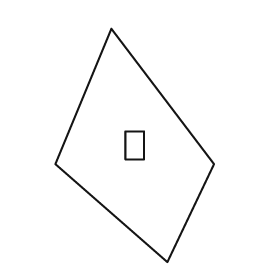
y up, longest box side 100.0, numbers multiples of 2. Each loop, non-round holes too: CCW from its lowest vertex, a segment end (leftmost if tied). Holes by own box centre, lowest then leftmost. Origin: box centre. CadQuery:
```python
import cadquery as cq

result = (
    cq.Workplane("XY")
    .moveTo(14.0, -50.0)
    .lineTo(34.0, -8.0)
    .lineTo(-10.0, 50.0)
    .lineTo(-34.0, -8.0)
    .close()
    .moveTo(-4.0, -6.0)
    .lineTo(4.0, -6.0)
    .lineTo(4.0, 6.0)
    .lineTo(-4.0, 6.0)
    .close()
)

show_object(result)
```